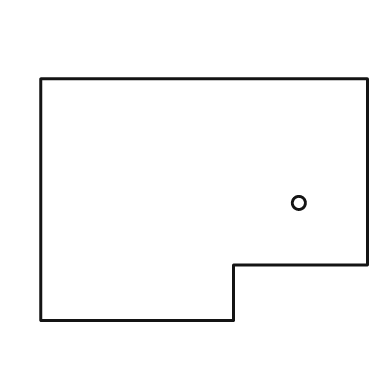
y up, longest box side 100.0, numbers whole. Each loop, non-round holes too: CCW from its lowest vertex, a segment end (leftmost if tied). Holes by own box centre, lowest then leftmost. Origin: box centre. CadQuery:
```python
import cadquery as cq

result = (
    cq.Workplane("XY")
    .moveTo(-50.0, -37.0)
    .lineTo(9.0, -37.0)
    .lineTo(9.0, -20.0)
    .lineTo(50.0, -20.0)
    .lineTo(50.0, 37.0)
    .lineTo(-50.0, 37.0)
    .close()
    .moveTo(29.0, -1.0)
    .circle(2.0)
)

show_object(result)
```